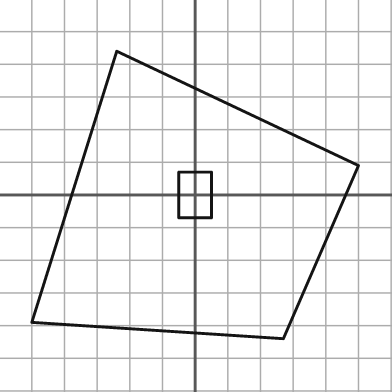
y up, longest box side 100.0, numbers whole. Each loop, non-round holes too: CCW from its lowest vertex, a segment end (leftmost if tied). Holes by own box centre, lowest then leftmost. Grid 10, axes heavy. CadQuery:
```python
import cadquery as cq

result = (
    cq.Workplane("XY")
    .moveTo(27.0, -44.0)
    .lineTo(50.0, 9.0)
    .lineTo(-24.0, 44.0)
    .lineTo(-50.0, -39.0)
    .close()
    .moveTo(-5.0, -7.0)
    .lineTo(5.0, -7.0)
    .lineTo(5.0, 7.0)
    .lineTo(-5.0, 7.0)
    .close()
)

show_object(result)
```